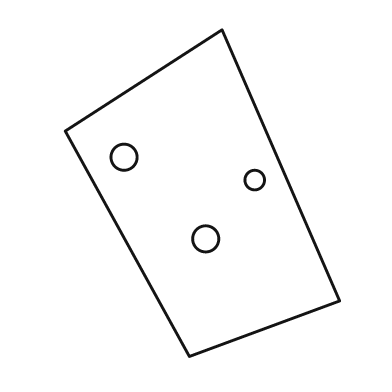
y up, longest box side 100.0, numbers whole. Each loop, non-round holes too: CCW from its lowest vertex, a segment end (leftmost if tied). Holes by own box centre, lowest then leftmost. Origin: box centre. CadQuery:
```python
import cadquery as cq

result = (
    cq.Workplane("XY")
    .moveTo(-4.0, -50.0)
    .lineTo(42.0, -33.0)
    .lineTo(6.0, 50.0)
    .lineTo(-42.0, 19.0)
    .close()
    .moveTo(1.0, -14.0)
    .circle(4.0)
    .moveTo(16.0, 4.0)
    .circle(3.0)
    .moveTo(-24.0, 11.0)
    .circle(4.0)
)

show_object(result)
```